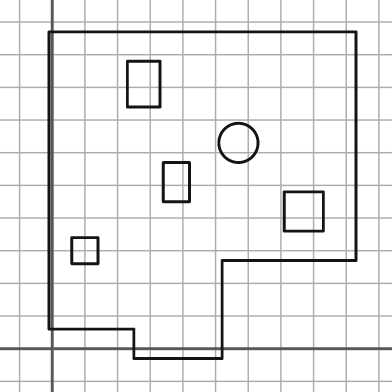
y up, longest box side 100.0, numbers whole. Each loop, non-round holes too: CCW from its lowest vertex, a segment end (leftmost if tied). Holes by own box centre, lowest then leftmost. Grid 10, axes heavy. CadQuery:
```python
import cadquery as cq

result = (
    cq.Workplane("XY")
    .moveTo(25.0, -3.0)
    .lineTo(52.0, -3.0)
    .lineTo(52.0, 27.0)
    .lineTo(93.0, 27.0)
    .lineTo(93.0, 97.0)
    .lineTo(-1.0, 97.0)
    .lineTo(-1.0, 6.0)
    .lineTo(25.0, 6.0)
    .close()
    .moveTo(6.0, 26.0)
    .lineTo(14.0, 26.0)
    .lineTo(14.0, 34.0)
    .lineTo(6.0, 34.0)
    .close()
    .moveTo(71.0, 36.0)
    .lineTo(83.0, 36.0)
    .lineTo(83.0, 48.0)
    .lineTo(71.0, 48.0)
    .close()
    .moveTo(34.0, 45.0)
    .lineTo(42.0, 45.0)
    .lineTo(42.0, 57.0)
    .lineTo(34.0, 57.0)
    .close()
    .moveTo(57.0, 63.0)
    .circle(6.0)
    .moveTo(23.0, 74.0)
    .lineTo(33.0, 74.0)
    .lineTo(33.0, 88.0)
    .lineTo(23.0, 88.0)
    .close()
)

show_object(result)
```